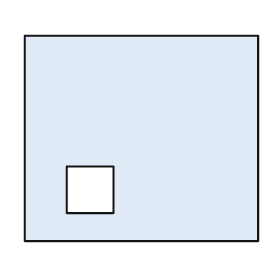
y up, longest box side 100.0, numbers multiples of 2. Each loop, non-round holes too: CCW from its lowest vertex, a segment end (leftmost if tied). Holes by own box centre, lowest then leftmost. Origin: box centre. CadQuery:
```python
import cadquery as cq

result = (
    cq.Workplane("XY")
    .moveTo(-50.0, -44.0)
    .lineTo(50.0, -44.0)
    .lineTo(50.0, 44.0)
    .lineTo(-50.0, 44.0)
    .close()
    .moveTo(-32.0, -32.0)
    .lineTo(-12.0, -32.0)
    .lineTo(-12.0, -12.0)
    .lineTo(-32.0, -12.0)
    .close()
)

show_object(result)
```